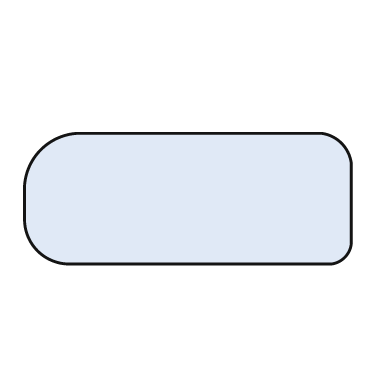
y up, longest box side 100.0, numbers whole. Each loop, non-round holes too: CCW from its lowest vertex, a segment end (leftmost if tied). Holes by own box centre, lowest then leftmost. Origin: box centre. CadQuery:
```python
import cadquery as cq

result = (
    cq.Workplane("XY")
    .moveTo(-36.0, -20.0)
    .lineTo(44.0, -20.0)
    .threePointArc((48.0, -18.0), (50.0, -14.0))
    .lineTo(50.0, 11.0)
    .threePointArc((47.0, 17.0), (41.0, 20.0))
    .lineTo(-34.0, 20.0)
    .threePointArc((-45.0, 15.0), (-50.0, 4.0))
    .lineTo(-50.0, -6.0)
    .threePointArc((-46.0, -16.0), (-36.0, -20.0))
    .close()
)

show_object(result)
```